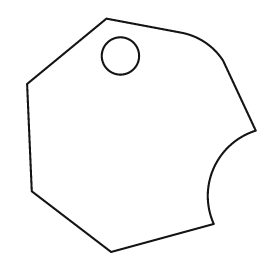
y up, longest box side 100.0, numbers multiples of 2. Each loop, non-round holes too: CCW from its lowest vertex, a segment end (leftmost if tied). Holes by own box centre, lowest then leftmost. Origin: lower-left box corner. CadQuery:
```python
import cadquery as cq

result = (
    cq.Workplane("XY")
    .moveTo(36.0, 0.0)
    .lineTo(80.0, 12.0)
    .threePointArc((80.0, 36.0), (98.0, 52.0))
    .lineTo(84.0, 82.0)
    .threePointArc((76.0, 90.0), (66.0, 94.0))
    .lineTo(34.0, 100.0)
    .lineTo(0.0, 72.0)
    .lineTo(2.0, 26.0)
    .close()
    .moveTo(40.0, 84.0)
    .circle(8.0)
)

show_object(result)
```